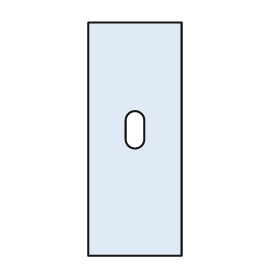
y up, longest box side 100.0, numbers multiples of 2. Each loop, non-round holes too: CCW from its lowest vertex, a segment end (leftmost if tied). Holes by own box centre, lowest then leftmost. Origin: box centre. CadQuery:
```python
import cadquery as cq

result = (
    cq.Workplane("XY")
    .moveTo(-20.0, -50.0)
    .lineTo(20.0, -50.0)
    .lineTo(20.0, 50.0)
    .lineTo(-20.0, 50.0)
    .close()
    .moveTo(-4.0, 0.0)
    .threePointArc((0.0, -4.0), (4.0, 0.0))
    .lineTo(4.0, 8.0)
    .threePointArc((0.0, 12.0), (-4.0, 8.0))
    .close()
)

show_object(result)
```